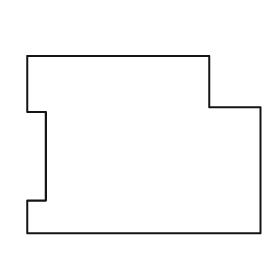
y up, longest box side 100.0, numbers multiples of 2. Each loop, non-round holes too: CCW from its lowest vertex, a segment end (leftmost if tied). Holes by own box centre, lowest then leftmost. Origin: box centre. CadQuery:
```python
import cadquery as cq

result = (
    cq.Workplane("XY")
    .moveTo(-50.0, -38.0)
    .lineTo(50.0, -38.0)
    .lineTo(50.0, 16.0)
    .lineTo(28.0, 16.0)
    .lineTo(28.0, 38.0)
    .lineTo(-50.0, 38.0)
    .lineTo(-50.0, 14.0)
    .lineTo(-42.0, 14.0)
    .lineTo(-42.0, -24.0)
    .lineTo(-50.0, -24.0)
    .close()
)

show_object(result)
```